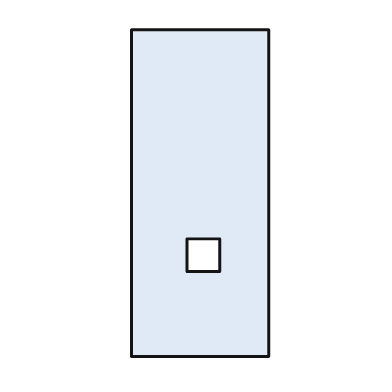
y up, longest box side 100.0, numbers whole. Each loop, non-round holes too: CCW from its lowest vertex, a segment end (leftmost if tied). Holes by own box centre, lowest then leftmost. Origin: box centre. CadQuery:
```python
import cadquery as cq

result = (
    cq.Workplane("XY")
    .moveTo(-21.0, -50.0)
    .lineTo(21.0, -50.0)
    .lineTo(21.0, 50.0)
    .lineTo(-21.0, 50.0)
    .close()
    .moveTo(-4.0, -24.0)
    .lineTo(6.0, -24.0)
    .lineTo(6.0, -14.0)
    .lineTo(-4.0, -14.0)
    .close()
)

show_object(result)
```